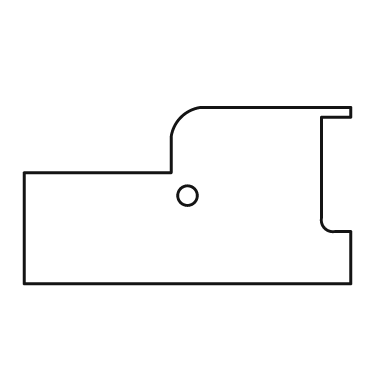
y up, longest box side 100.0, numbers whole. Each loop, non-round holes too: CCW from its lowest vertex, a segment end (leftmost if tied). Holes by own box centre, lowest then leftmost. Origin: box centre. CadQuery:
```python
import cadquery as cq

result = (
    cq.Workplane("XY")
    .moveTo(-50.0, -27.0)
    .lineTo(50.0, -27.0)
    .lineTo(50.0, -11.0)
    .lineTo(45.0, -11.0)
    .threePointArc((42.0, -10.0), (41.0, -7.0))
    .lineTo(41.0, 24.0)
    .lineTo(50.0, 24.0)
    .lineTo(50.0, 27.0)
    .lineTo(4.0, 27.0)
    .threePointArc((-2.0, 24.0), (-5.0, 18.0))
    .lineTo(-5.0, 7.0)
    .lineTo(-50.0, 7.0)
    .close()
    .moveTo(0.0, 0.0)
    .circle(3.0)
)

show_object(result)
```